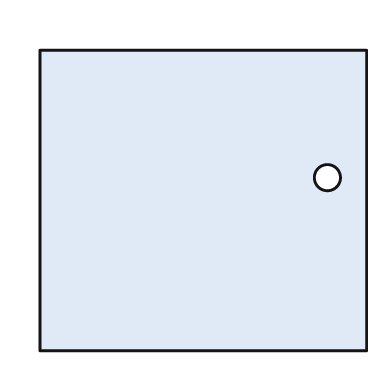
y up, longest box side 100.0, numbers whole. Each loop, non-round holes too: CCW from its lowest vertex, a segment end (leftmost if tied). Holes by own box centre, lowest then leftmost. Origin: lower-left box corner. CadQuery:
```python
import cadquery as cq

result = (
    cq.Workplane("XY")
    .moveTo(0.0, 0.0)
    .lineTo(100.0, 0.0)
    .lineTo(100.0, 92.0)
    .lineTo(0.0, 92.0)
    .close()
    .moveTo(88.0, 53.0)
    .circle(4.0)
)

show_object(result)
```